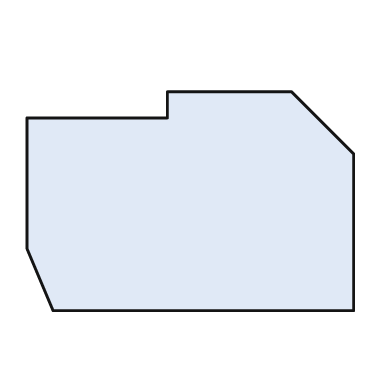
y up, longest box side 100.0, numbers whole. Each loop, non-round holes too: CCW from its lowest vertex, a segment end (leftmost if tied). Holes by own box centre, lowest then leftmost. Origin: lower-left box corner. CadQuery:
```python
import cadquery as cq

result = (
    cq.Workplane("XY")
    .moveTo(8.0, 0.0)
    .lineTo(100.0, 0.0)
    .lineTo(100.0, 48.0)
    .lineTo(81.0, 67.0)
    .lineTo(43.0, 67.0)
    .lineTo(43.0, 59.0)
    .lineTo(0.0, 59.0)
    .lineTo(0.0, 19.0)
    .close()
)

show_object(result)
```